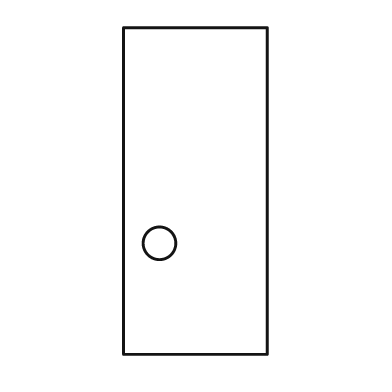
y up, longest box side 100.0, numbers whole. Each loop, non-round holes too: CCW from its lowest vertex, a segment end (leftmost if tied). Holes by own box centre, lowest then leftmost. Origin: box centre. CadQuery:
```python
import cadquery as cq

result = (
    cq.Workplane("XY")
    .moveTo(-22.0, -50.0)
    .lineTo(22.0, -50.0)
    .lineTo(22.0, 50.0)
    .lineTo(-22.0, 50.0)
    .close()
    .moveTo(-11.0, -16.0)
    .circle(5.0)
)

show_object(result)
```